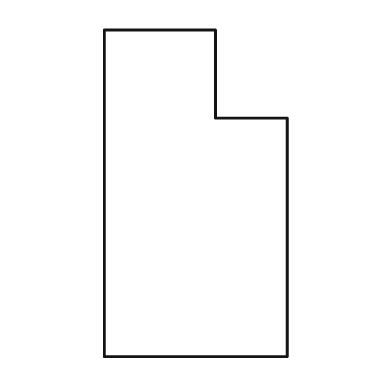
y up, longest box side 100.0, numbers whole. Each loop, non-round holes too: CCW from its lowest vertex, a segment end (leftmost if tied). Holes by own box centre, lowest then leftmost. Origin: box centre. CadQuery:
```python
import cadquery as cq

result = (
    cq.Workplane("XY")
    .moveTo(-28.0, -50.0)
    .lineTo(28.0, -50.0)
    .lineTo(28.0, 23.0)
    .lineTo(6.0, 23.0)
    .lineTo(6.0, 50.0)
    .lineTo(-28.0, 50.0)
    .close()
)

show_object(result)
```